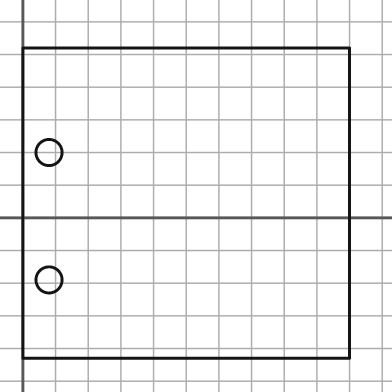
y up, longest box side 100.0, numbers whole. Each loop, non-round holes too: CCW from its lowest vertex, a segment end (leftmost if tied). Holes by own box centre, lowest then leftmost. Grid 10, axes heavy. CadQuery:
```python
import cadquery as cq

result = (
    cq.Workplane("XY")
    .moveTo(0.0, -43.0)
    .lineTo(100.0, -43.0)
    .lineTo(100.0, 52.0)
    .lineTo(0.0, 52.0)
    .close()
    .moveTo(8.0, -19.0)
    .circle(4.0)
    .moveTo(8.0, 20.0)
    .circle(4.0)
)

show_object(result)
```